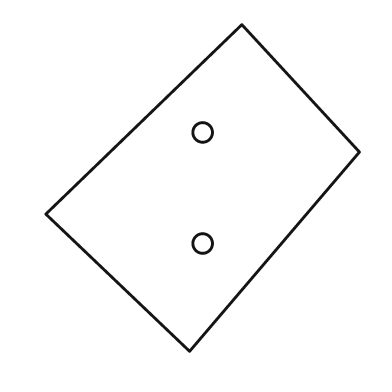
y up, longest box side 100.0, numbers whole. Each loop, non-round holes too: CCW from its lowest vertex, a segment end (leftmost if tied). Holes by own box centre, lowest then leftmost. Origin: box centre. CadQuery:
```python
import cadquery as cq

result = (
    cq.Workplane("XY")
    .moveTo(-4.0, -50.0)
    .lineTo(48.0, 11.0)
    .lineTo(12.0, 50.0)
    .lineTo(-48.0, -8.0)
    .close()
    .moveTo(0.0, -17.0)
    .circle(3.0)
    .moveTo(0.0, 17.0)
    .circle(3.0)
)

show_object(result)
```